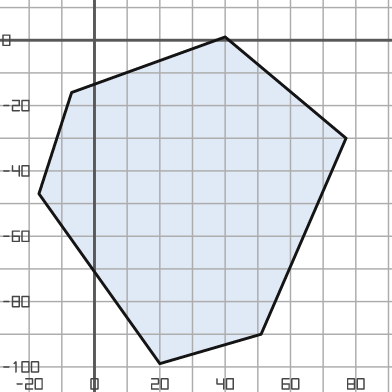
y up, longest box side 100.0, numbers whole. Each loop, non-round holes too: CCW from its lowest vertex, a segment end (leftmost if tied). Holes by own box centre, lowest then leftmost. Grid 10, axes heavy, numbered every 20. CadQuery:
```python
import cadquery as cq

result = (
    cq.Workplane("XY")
    .moveTo(20.0, -99.0)
    .lineTo(51.0, -90.0)
    .lineTo(77.0, -30.0)
    .lineTo(40.0, 1.0)
    .lineTo(-7.0, -16.0)
    .lineTo(-17.0, -47.0)
    .close()
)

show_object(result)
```